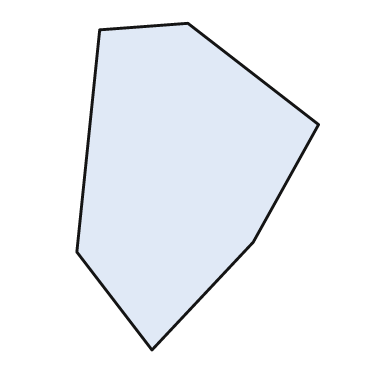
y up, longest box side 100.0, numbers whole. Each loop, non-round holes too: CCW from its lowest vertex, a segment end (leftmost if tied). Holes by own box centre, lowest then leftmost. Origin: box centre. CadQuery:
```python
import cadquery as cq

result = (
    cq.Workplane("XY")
    .moveTo(-14.0, -50.0)
    .lineTo(17.0, -17.0)
    .lineTo(37.0, 19.0)
    .lineTo(-3.0, 50.0)
    .lineTo(-30.0, 48.0)
    .lineTo(-37.0, -20.0)
    .close()
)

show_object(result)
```